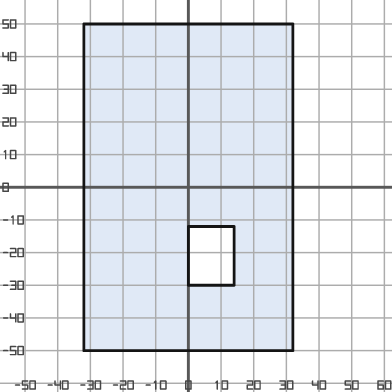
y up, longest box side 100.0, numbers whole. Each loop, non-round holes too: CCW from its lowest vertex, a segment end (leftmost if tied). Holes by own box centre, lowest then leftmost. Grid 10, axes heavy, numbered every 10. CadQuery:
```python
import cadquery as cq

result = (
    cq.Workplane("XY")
    .moveTo(-32.0, -50.0)
    .lineTo(32.0, -50.0)
    .lineTo(32.0, 50.0)
    .lineTo(-32.0, 50.0)
    .close()
    .moveTo(0.0, -30.0)
    .lineTo(14.0, -30.0)
    .lineTo(14.0, -12.0)
    .lineTo(0.0, -12.0)
    .close()
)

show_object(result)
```